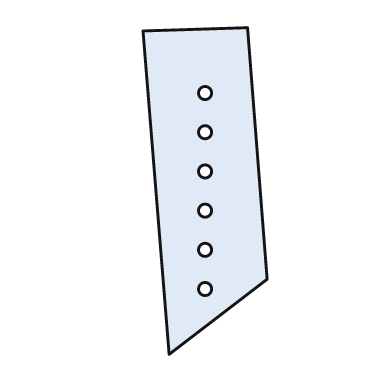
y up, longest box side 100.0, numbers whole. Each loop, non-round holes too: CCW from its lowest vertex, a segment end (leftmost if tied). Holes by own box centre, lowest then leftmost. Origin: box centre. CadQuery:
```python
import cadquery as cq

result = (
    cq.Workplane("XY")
    .moveTo(-11.0, -50.0)
    .lineTo(19.0, -27.0)
    .lineTo(13.0, 50.0)
    .lineTo(-19.0, 49.0)
    .close()
    .moveTo(0.0, -30.0)
    .circle(2.0)
    .moveTo(0.0, -18.0)
    .circle(2.0)
    .moveTo(0.0, -6.0)
    .circle(2.0)
    .moveTo(0.0, 6.0)
    .circle(2.0)
    .moveTo(0.0, 18.0)
    .circle(2.0)
    .moveTo(0.0, 30.0)
    .circle(2.0)
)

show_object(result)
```